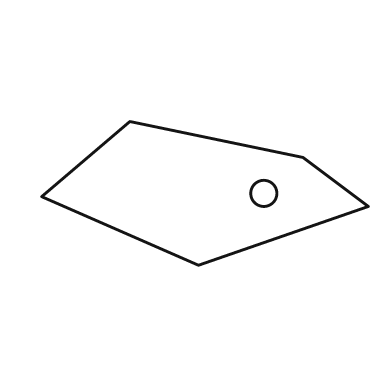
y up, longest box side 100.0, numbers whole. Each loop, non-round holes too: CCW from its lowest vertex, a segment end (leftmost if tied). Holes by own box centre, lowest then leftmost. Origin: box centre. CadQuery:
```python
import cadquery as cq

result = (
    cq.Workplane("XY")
    .moveTo(-2.0, -22.0)
    .lineTo(50.0, -4.0)
    .lineTo(30.0, 11.0)
    .lineTo(-23.0, 22.0)
    .lineTo(-50.0, -1.0)
    .close()
    .moveTo(18.0, 0.0)
    .circle(4.0)
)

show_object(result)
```